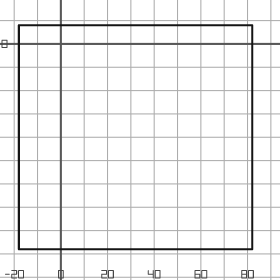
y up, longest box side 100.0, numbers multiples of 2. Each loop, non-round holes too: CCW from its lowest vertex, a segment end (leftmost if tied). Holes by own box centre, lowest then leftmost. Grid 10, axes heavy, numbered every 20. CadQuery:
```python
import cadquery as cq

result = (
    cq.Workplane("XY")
    .moveTo(-18.0, -88.0)
    .lineTo(82.0, -88.0)
    .lineTo(82.0, 8.0)
    .lineTo(-18.0, 8.0)
    .close()
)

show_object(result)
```